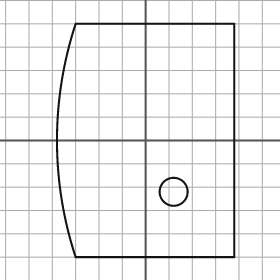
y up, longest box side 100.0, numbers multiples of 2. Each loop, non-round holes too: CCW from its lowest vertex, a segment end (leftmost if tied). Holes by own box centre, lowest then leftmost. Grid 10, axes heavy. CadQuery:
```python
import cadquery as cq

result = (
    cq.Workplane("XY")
    .moveTo(-30.0, -50.0)
    .lineTo(38.0, -50.0)
    .lineTo(38.0, 50.0)
    .lineTo(-30.0, 50.0)
    .threePointArc((-38.0, 0.0), (-30.0, -50.0))
    .close()
    .moveTo(12.0, -22.0)
    .circle(6.0)
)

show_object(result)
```